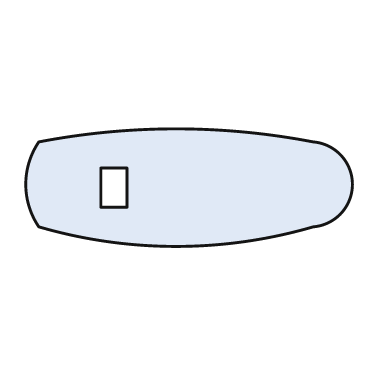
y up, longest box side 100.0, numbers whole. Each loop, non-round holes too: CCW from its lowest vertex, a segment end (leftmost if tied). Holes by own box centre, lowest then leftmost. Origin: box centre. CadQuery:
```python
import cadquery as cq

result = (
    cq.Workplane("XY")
    .moveTo(-46.0, -12.0)
    .threePointArc((-4.0, -18.0), (38.0, -12.0))
    .threePointArc((50.0, 1.0), (38.0, 14.0))
    .threePointArc((-4.0, 18.0), (-46.0, 14.0))
    .threePointArc((-50.0, 1.0), (-46.0, -12.0))
    .close()
    .moveTo(-27.0, -6.0)
    .lineTo(-19.0, -6.0)
    .lineTo(-19.0, 6.0)
    .lineTo(-27.0, 6.0)
    .close()
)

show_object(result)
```